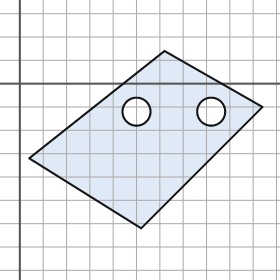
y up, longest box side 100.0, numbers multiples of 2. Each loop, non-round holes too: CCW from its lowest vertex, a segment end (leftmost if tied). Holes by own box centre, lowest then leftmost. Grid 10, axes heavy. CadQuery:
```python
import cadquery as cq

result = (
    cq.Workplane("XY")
    .moveTo(52.0, -62.0)
    .lineTo(104.0, -10.0)
    .lineTo(62.0, 14.0)
    .lineTo(4.0, -32.0)
    .close()
    .moveTo(50.0, -12.0)
    .circle(6.0)
    .moveTo(82.0, -12.0)
    .circle(6.0)
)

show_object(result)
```